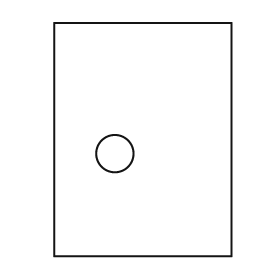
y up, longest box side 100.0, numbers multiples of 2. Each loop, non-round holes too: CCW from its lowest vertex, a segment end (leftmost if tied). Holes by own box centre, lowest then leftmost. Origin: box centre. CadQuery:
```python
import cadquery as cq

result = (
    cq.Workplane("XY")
    .moveTo(-38.0, -50.0)
    .lineTo(38.0, -50.0)
    .lineTo(38.0, 50.0)
    .lineTo(-38.0, 50.0)
    .close()
    .moveTo(-12.0, -6.0)
    .circle(8.0)
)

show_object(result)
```